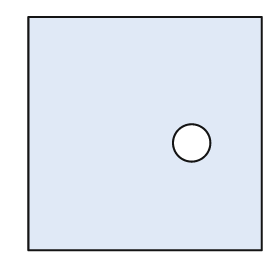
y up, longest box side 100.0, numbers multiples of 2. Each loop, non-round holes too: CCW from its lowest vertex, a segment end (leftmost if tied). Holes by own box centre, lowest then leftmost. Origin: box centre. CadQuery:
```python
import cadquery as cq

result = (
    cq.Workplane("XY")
    .moveTo(-50.0, -50.0)
    .lineTo(50.0, -50.0)
    .lineTo(50.0, 50.0)
    .lineTo(-50.0, 50.0)
    .close()
    .moveTo(20.0, -4.0)
    .circle(8.0)
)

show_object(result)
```